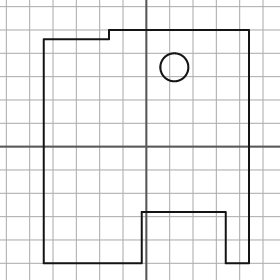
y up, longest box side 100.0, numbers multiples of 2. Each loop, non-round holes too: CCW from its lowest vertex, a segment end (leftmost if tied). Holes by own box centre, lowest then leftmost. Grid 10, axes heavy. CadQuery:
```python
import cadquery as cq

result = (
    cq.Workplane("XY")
    .moveTo(-44.0, -50.0)
    .lineTo(-2.0, -50.0)
    .lineTo(-2.0, -28.0)
    .lineTo(34.0, -28.0)
    .lineTo(34.0, -50.0)
    .lineTo(44.0, -50.0)
    .lineTo(44.0, 50.0)
    .lineTo(-16.0, 50.0)
    .lineTo(-16.0, 46.0)
    .lineTo(-44.0, 46.0)
    .close()
    .moveTo(12.0, 34.0)
    .circle(6.0)
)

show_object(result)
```